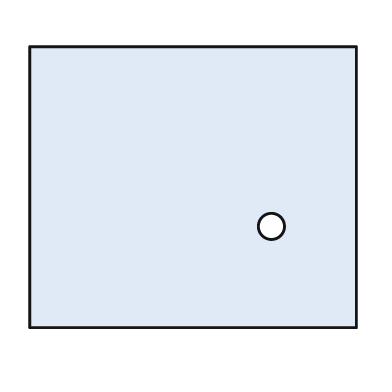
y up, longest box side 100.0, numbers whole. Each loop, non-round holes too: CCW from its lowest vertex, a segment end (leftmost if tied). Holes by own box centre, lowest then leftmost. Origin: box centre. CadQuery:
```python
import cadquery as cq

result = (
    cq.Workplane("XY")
    .moveTo(-50.0, -43.0)
    .lineTo(50.0, -43.0)
    .lineTo(50.0, 43.0)
    .lineTo(-50.0, 43.0)
    .close()
    .moveTo(24.0, -12.0)
    .circle(4.0)
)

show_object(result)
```